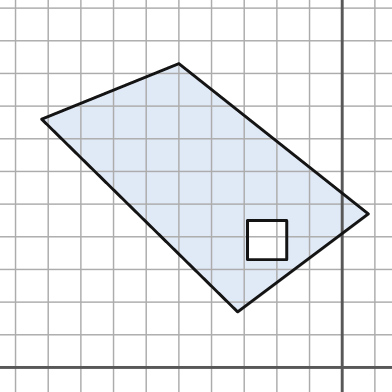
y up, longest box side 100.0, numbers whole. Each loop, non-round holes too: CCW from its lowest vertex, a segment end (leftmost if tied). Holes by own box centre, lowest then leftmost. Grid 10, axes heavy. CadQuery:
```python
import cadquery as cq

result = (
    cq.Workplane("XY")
    .moveTo(-32.0, 17.0)
    .lineTo(8.0, 47.0)
    .lineTo(-50.0, 93.0)
    .lineTo(-92.0, 76.0)
    .close()
    .moveTo(-29.0, 33.0)
    .lineTo(-17.0, 33.0)
    .lineTo(-17.0, 45.0)
    .lineTo(-29.0, 45.0)
    .close()
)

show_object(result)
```